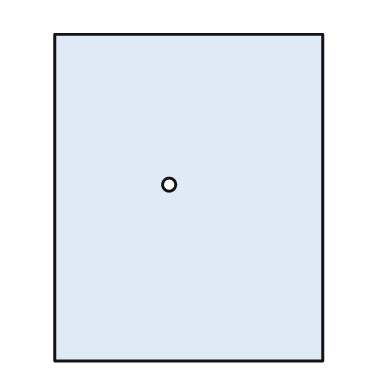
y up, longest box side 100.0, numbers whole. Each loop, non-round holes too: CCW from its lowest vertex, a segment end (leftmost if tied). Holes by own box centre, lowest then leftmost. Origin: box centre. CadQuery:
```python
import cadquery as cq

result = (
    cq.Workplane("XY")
    .moveTo(-41.0, -50.0)
    .lineTo(41.0, -50.0)
    .lineTo(41.0, 50.0)
    .lineTo(-41.0, 50.0)
    .close()
    .moveTo(-6.0, 4.0)
    .circle(2.0)
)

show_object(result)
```